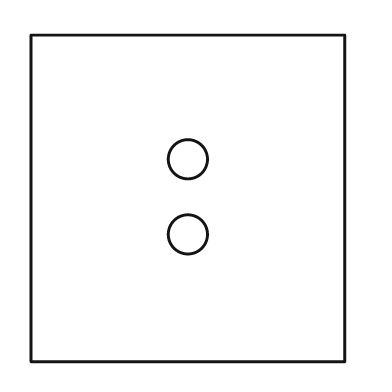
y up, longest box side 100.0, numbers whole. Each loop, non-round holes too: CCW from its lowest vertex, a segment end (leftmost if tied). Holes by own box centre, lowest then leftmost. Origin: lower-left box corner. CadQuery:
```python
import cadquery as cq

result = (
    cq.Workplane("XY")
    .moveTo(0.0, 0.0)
    .lineTo(96.0, 0.0)
    .lineTo(96.0, 100.0)
    .lineTo(0.0, 100.0)
    .close()
    .moveTo(48.0, 39.0)
    .circle(6.0)
    .moveTo(48.0, 62.0)
    .circle(6.0)
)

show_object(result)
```